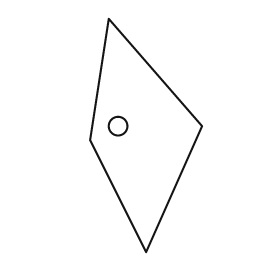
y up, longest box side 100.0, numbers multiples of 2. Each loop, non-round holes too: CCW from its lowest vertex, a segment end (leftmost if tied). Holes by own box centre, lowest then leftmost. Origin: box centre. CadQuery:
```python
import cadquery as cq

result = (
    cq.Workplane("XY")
    .moveTo(0.0, -50.0)
    .lineTo(24.0, 4.0)
    .lineTo(-16.0, 50.0)
    .lineTo(-24.0, -2.0)
    .close()
    .moveTo(-12.0, 4.0)
    .circle(4.0)
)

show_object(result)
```